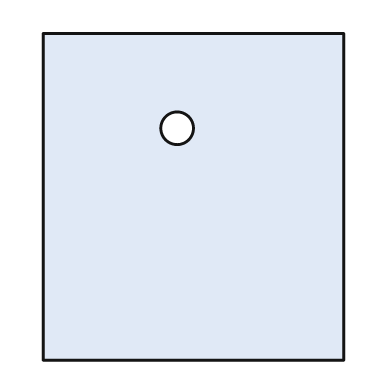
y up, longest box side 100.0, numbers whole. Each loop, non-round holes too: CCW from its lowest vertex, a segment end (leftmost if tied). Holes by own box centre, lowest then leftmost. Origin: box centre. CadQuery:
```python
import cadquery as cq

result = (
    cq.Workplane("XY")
    .moveTo(-46.0, -50.0)
    .lineTo(46.0, -50.0)
    .lineTo(46.0, 50.0)
    .lineTo(-46.0, 50.0)
    .close()
    .moveTo(-5.0, 21.0)
    .circle(5.0)
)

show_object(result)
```